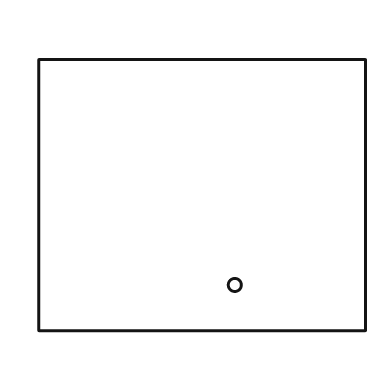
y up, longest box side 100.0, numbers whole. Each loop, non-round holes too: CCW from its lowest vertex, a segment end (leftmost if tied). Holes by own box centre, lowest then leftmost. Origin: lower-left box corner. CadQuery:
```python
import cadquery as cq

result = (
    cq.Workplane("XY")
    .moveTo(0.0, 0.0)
    .lineTo(100.0, 0.0)
    .lineTo(100.0, 83.0)
    .lineTo(0.0, 83.0)
    .close()
    .moveTo(60.0, 14.0)
    .circle(2.0)
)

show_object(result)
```